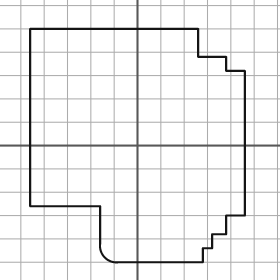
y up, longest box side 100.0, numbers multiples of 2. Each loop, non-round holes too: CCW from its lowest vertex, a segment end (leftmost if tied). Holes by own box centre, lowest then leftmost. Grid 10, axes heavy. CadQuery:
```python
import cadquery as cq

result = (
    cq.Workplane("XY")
    .moveTo(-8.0, -50.0)
    .lineTo(28.0, -50.0)
    .lineTo(28.0, -44.0)
    .lineTo(32.0, -44.0)
    .lineTo(32.0, -38.0)
    .lineTo(38.0, -38.0)
    .lineTo(38.0, -30.0)
    .lineTo(46.0, -30.0)
    .lineTo(46.0, 32.0)
    .lineTo(38.0, 32.0)
    .lineTo(38.0, 38.0)
    .lineTo(26.0, 38.0)
    .lineTo(26.0, 50.0)
    .lineTo(-46.0, 50.0)
    .lineTo(-46.0, -26.0)
    .lineTo(-16.0, -26.0)
    .lineTo(-16.0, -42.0)
    .threePointArc((-14.0, -48.0), (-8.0, -50.0))
    .close()
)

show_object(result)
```